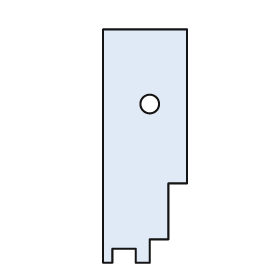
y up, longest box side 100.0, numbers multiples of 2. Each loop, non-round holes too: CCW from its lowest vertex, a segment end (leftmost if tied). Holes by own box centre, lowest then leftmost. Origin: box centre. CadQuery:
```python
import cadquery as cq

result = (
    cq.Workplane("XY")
    .moveTo(-18.0, -50.0)
    .lineTo(-14.0, -50.0)
    .lineTo(-14.0, -44.0)
    .lineTo(-4.0, -44.0)
    .lineTo(-4.0, -50.0)
    .lineTo(2.0, -50.0)
    .lineTo(2.0, -40.0)
    .lineTo(10.0, -40.0)
    .lineTo(10.0, -16.0)
    .lineTo(18.0, -16.0)
    .lineTo(18.0, 50.0)
    .lineTo(-18.0, 50.0)
    .close()
    .moveTo(2.0, 18.0)
    .circle(4.0)
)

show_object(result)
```